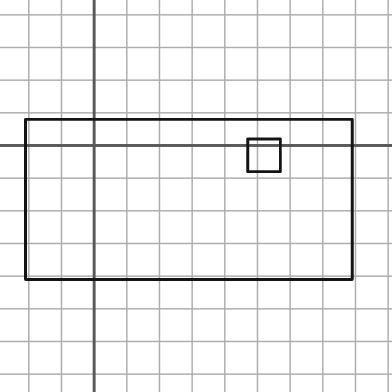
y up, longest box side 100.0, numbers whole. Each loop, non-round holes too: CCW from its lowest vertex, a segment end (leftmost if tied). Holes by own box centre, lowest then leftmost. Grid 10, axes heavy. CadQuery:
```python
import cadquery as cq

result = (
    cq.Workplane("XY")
    .moveTo(-21.0, -41.0)
    .lineTo(79.0, -41.0)
    .lineTo(79.0, 8.0)
    .lineTo(-21.0, 8.0)
    .close()
    .moveTo(47.0, -8.0)
    .lineTo(57.0, -8.0)
    .lineTo(57.0, 2.0)
    .lineTo(47.0, 2.0)
    .close()
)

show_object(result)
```